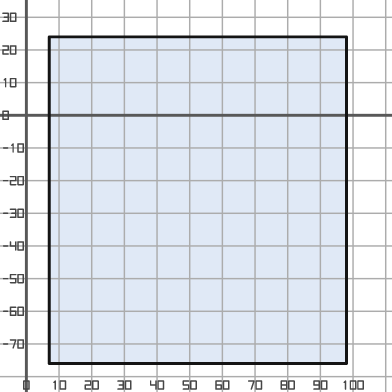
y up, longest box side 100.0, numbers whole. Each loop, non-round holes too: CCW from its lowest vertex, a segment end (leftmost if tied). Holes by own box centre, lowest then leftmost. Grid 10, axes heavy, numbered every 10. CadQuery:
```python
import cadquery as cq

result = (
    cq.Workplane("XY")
    .moveTo(7.0, -76.0)
    .lineTo(98.0, -76.0)
    .lineTo(98.0, 24.0)
    .lineTo(7.0, 24.0)
    .close()
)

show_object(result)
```